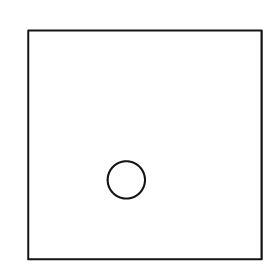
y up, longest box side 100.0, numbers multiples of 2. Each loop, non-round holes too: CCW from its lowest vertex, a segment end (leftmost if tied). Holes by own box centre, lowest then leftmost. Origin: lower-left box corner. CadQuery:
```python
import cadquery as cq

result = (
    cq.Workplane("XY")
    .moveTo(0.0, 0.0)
    .lineTo(100.0, 0.0)
    .lineTo(100.0, 98.0)
    .lineTo(0.0, 98.0)
    .close()
    .moveTo(42.0, 34.0)
    .circle(8.0)
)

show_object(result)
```